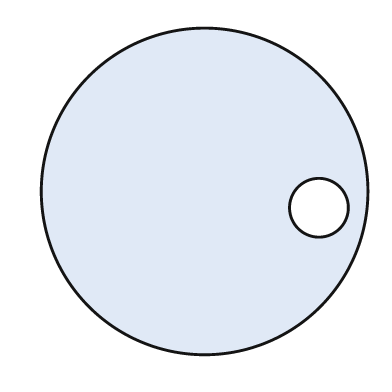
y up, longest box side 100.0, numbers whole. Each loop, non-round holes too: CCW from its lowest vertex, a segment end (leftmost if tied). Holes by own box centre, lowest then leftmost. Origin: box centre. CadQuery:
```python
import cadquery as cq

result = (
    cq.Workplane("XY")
    .moveTo(0.0, 0.0)
    .circle(50.0)
    .moveTo(35.0, -5.0)
    .circle(9.0)
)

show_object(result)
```